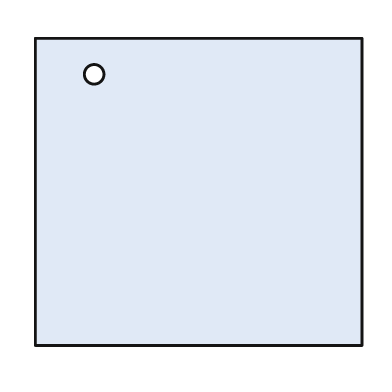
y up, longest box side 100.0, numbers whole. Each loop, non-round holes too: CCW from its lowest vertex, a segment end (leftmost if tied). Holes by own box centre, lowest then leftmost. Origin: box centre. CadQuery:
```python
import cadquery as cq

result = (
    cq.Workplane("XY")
    .moveTo(-50.0, -47.0)
    .lineTo(50.0, -47.0)
    .lineTo(50.0, 47.0)
    .lineTo(-50.0, 47.0)
    .close()
    .moveTo(-32.0, 36.0)
    .circle(3.0)
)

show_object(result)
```